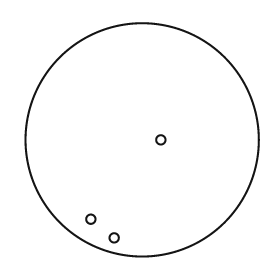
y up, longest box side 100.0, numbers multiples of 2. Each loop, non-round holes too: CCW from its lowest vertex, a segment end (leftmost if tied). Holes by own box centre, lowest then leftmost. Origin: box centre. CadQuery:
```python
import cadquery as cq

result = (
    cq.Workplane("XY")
    .moveTo(0.0, 0.0)
    .circle(50.0)
    .moveTo(-12.0, -42.0)
    .circle(2.0)
    .moveTo(-22.0, -34.0)
    .circle(2.0)
    .moveTo(8.0, 0.0)
    .circle(2.0)
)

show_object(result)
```